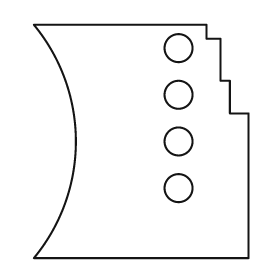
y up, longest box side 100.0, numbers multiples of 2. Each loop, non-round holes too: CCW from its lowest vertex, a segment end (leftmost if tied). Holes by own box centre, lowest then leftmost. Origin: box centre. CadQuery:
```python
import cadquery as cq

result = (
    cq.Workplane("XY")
    .moveTo(-46.0, -50.0)
    .lineTo(46.0, -50.0)
    .lineTo(46.0, 12.0)
    .lineTo(38.0, 12.0)
    .lineTo(38.0, 26.0)
    .lineTo(34.0, 26.0)
    .lineTo(34.0, 44.0)
    .lineTo(28.0, 44.0)
    .lineTo(28.0, 50.0)
    .lineTo(-46.0, 50.0)
    .threePointArc((-28.0, 0.0), (-46.0, -50.0))
    .close()
    .moveTo(16.0, -20.0)
    .circle(6.0)
    .moveTo(16.0, 0.0)
    .circle(6.0)
    .moveTo(16.0, 20.0)
    .circle(6.0)
    .moveTo(16.0, 40.0)
    .circle(6.0)
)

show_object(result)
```